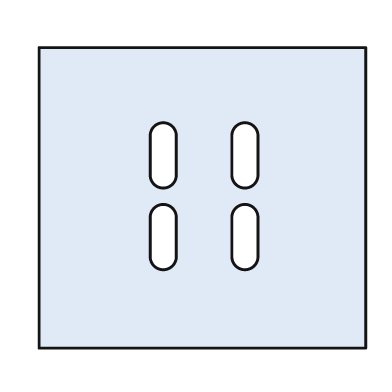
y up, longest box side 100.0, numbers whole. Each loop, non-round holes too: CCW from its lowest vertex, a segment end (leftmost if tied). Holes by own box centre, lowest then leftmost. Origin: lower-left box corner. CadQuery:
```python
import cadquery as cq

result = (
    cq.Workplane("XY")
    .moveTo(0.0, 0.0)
    .lineTo(100.0, 0.0)
    .lineTo(100.0, 92.0)
    .lineTo(0.0, 92.0)
    .close()
    .moveTo(34.0, 28.0)
    .threePointArc((38.0, 24.0), (42.0, 28.0))
    .lineTo(42.0, 40.0)
    .threePointArc((38.0, 44.0), (34.0, 40.0))
    .close()
    .moveTo(59.0, 28.0)
    .threePointArc((63.0, 24.0), (67.0, 28.0))
    .lineTo(67.0, 40.0)
    .threePointArc((63.0, 44.0), (59.0, 40.0))
    .close()
    .moveTo(34.0, 53.0)
    .threePointArc((38.0, 49.0), (42.0, 53.0))
    .lineTo(42.0, 65.0)
    .threePointArc((38.0, 69.0), (34.0, 65.0))
    .close()
    .moveTo(59.0, 53.0)
    .threePointArc((63.0, 49.0), (67.0, 53.0))
    .lineTo(67.0, 65.0)
    .threePointArc((63.0, 69.0), (59.0, 65.0))
    .close()
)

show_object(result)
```